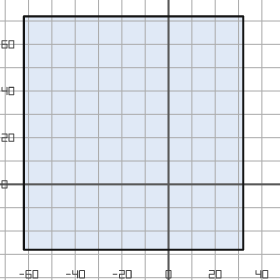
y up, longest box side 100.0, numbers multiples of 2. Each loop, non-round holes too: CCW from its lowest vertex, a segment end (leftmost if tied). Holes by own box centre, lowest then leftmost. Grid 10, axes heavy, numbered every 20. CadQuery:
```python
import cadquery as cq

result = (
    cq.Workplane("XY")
    .moveTo(-62.0, -28.0)
    .lineTo(32.0, -28.0)
    .lineTo(32.0, 72.0)
    .lineTo(-62.0, 72.0)
    .close()
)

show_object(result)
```